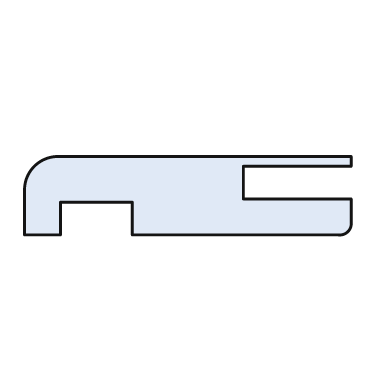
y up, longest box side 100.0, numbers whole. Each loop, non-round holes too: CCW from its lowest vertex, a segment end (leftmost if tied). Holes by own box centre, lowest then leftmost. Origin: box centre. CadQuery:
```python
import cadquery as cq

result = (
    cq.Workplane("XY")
    .moveTo(-50.0, -12.0)
    .lineTo(-39.0, -12.0)
    .lineTo(-39.0, -2.0)
    .lineTo(-17.0, -2.0)
    .lineTo(-17.0, -12.0)
    .lineTo(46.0, -12.0)
    .threePointArc((49.0, -11.0), (50.0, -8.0))
    .lineTo(50.0, -1.0)
    .lineTo(17.0, -1.0)
    .lineTo(17.0, 9.0)
    .lineTo(50.0, 9.0)
    .lineTo(50.0, 12.0)
    .lineTo(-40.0, 12.0)
    .threePointArc((-47.0, 9.0), (-50.0, 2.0))
    .close()
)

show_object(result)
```